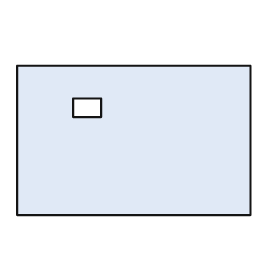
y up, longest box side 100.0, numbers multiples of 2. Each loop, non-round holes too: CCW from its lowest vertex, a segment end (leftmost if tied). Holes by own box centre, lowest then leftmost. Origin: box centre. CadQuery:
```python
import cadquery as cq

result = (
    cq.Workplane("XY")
    .moveTo(-50.0, -32.0)
    .lineTo(50.0, -32.0)
    .lineTo(50.0, 32.0)
    .lineTo(-50.0, 32.0)
    .close()
    .moveTo(-26.0, 10.0)
    .lineTo(-14.0, 10.0)
    .lineTo(-14.0, 18.0)
    .lineTo(-26.0, 18.0)
    .close()
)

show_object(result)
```